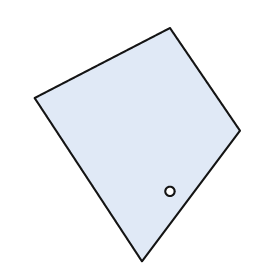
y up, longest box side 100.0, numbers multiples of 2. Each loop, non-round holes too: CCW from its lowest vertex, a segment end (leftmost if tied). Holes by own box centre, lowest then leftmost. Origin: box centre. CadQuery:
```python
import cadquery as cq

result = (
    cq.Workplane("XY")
    .moveTo(2.0, -50.0)
    .lineTo(44.0, 6.0)
    .lineTo(14.0, 50.0)
    .lineTo(-44.0, 20.0)
    .close()
    .moveTo(14.0, -20.0)
    .circle(2.0)
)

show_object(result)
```